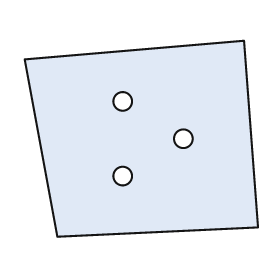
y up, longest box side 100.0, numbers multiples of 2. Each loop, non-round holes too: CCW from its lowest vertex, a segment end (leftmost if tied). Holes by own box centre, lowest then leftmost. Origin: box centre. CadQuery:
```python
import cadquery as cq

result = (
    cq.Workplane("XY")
    .moveTo(-36.0, -42.0)
    .lineTo(50.0, -38.0)
    .lineTo(44.0, 42.0)
    .lineTo(-50.0, 34.0)
    .close()
    .moveTo(-8.0, -16.0)
    .circle(4.0)
    .moveTo(18.0, 0.0)
    .circle(4.0)
    .moveTo(-8.0, 16.0)
    .circle(4.0)
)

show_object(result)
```